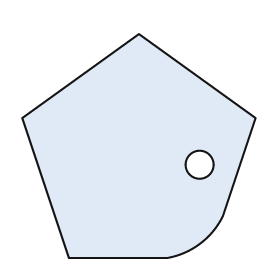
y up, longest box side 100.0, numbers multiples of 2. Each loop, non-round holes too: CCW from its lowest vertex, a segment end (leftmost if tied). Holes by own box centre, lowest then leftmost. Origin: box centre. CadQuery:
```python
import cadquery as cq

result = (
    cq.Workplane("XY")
    .moveTo(-30.0, -48.0)
    .lineTo(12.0, -48.0)
    .threePointArc((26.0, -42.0), (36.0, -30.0))
    .lineTo(50.0, 12.0)
    .lineTo(0.0, 48.0)
    .lineTo(-50.0, 12.0)
    .close()
    .moveTo(26.0, -8.0)
    .circle(6.0)
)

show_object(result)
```